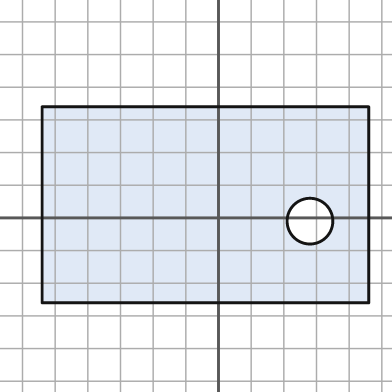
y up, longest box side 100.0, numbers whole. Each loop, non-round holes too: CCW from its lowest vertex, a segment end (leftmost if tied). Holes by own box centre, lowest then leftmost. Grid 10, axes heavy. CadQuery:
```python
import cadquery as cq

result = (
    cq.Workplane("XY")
    .moveTo(-54.0, -26.0)
    .lineTo(46.0, -26.0)
    .lineTo(46.0, 34.0)
    .lineTo(-54.0, 34.0)
    .close()
    .moveTo(28.0, -1.0)
    .circle(7.0)
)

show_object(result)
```